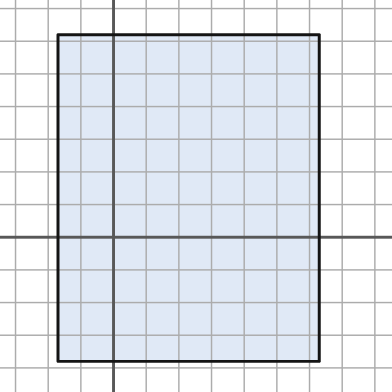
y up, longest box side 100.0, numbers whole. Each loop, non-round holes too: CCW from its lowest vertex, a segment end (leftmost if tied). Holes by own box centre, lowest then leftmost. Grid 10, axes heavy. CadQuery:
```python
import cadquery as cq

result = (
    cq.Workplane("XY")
    .moveTo(-17.0, -38.0)
    .lineTo(63.0, -38.0)
    .lineTo(63.0, 62.0)
    .lineTo(-17.0, 62.0)
    .close()
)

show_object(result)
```